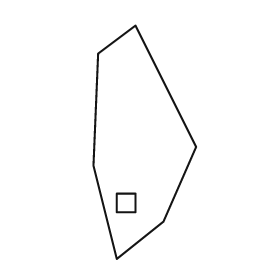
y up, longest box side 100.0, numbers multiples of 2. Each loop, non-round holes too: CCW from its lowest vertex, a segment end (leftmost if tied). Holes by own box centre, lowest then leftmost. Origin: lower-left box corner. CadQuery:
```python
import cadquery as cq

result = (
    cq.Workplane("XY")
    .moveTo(10.0, 0.0)
    .lineTo(30.0, 16.0)
    .lineTo(44.0, 48.0)
    .lineTo(18.0, 100.0)
    .lineTo(2.0, 88.0)
    .lineTo(0.0, 40.0)
    .close()
    .moveTo(10.0, 20.0)
    .lineTo(18.0, 20.0)
    .lineTo(18.0, 28.0)
    .lineTo(10.0, 28.0)
    .close()
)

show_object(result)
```